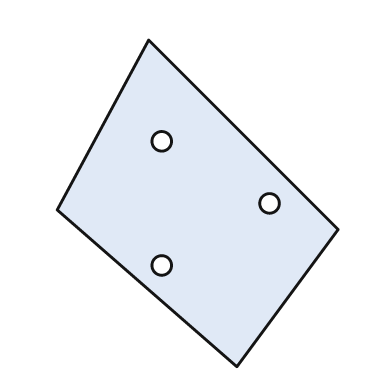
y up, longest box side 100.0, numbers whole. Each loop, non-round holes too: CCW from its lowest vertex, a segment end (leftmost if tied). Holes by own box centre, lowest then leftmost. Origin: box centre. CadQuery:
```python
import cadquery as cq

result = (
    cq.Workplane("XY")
    .moveTo(12.0, -50.0)
    .lineTo(43.0, -8.0)
    .lineTo(-15.0, 50.0)
    .lineTo(-43.0, -2.0)
    .close()
    .moveTo(-11.0, -19.0)
    .circle(3.0)
    .moveTo(22.0, 0.0)
    .circle(3.0)
    .moveTo(-11.0, 19.0)
    .circle(3.0)
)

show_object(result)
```